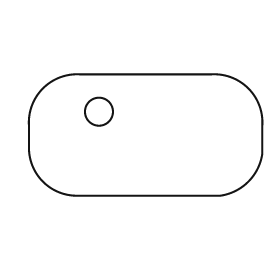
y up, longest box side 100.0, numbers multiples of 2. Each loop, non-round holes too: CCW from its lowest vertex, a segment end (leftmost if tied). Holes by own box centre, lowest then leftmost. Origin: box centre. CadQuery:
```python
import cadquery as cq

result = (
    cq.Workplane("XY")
    .moveTo(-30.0, -26.0)
    .lineTo(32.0, -26.0)
    .threePointArc((44.0, -20.0), (50.0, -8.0))
    .lineTo(50.0, 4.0)
    .threePointArc((44.0, 20.0), (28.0, 26.0))
    .lineTo(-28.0, 26.0)
    .threePointArc((-44.0, 20.0), (-50.0, 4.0))
    .lineTo(-50.0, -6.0)
    .threePointArc((-44.0, -20.0), (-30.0, -26.0))
    .close()
    .moveTo(-20.0, 10.0)
    .circle(6.0)
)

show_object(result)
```